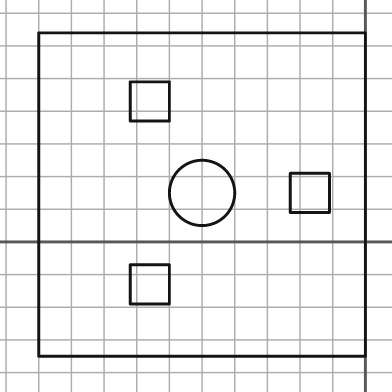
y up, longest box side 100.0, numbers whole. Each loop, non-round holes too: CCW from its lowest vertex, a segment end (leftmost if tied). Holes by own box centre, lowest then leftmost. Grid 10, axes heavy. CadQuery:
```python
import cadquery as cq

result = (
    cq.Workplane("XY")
    .moveTo(-100.0, -35.0)
    .lineTo(0.0, -35.0)
    .lineTo(0.0, 64.0)
    .lineTo(-100.0, 64.0)
    .close()
    .moveTo(-72.0, -19.0)
    .lineTo(-60.0, -19.0)
    .lineTo(-60.0, -7.0)
    .lineTo(-72.0, -7.0)
    .close()
    .moveTo(-50.0, 15.0)
    .circle(10.0)
    .moveTo(-23.0, 9.0)
    .lineTo(-11.0, 9.0)
    .lineTo(-11.0, 21.0)
    .lineTo(-23.0, 21.0)
    .close()
    .moveTo(-72.0, 37.0)
    .lineTo(-60.0, 37.0)
    .lineTo(-60.0, 49.0)
    .lineTo(-72.0, 49.0)
    .close()
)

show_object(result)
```